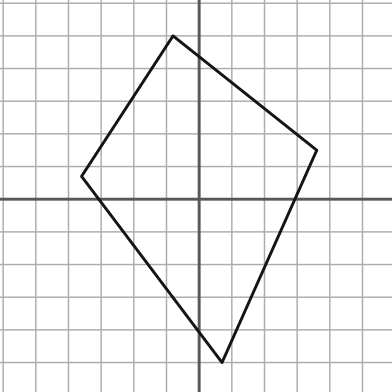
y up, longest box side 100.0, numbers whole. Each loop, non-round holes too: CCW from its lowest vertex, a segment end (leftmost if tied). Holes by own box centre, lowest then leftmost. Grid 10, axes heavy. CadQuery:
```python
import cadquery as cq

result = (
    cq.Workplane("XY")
    .moveTo(7.0, -50.0)
    .lineTo(36.0, 15.0)
    .lineTo(-8.0, 50.0)
    .lineTo(-36.0, 7.0)
    .close()
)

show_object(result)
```